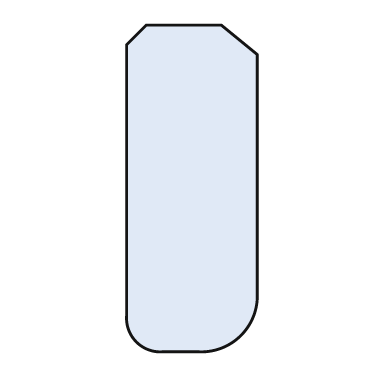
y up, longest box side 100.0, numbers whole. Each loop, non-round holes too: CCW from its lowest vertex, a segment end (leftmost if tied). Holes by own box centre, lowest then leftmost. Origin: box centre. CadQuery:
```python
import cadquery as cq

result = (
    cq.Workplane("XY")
    .moveTo(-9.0, -50.0)
    .lineTo(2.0, -50.0)
    .threePointArc((15.0, -45.0), (20.0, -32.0))
    .lineTo(20.0, 41.0)
    .lineTo(9.0, 50.0)
    .lineTo(-14.0, 50.0)
    .lineTo(-20.0, 44.0)
    .lineTo(-20.0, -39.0)
    .threePointArc((-17.0, -47.0), (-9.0, -50.0))
    .close()
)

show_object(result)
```